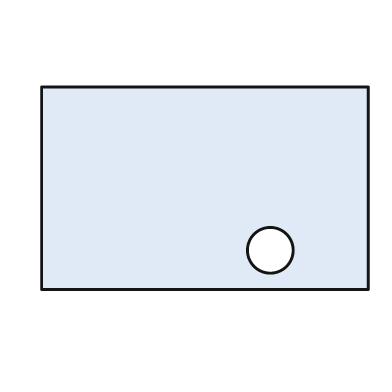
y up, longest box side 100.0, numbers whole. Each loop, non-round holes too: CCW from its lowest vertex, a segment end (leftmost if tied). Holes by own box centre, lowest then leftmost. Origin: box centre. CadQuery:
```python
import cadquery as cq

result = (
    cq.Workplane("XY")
    .moveTo(-50.0, -31.0)
    .lineTo(50.0, -31.0)
    .lineTo(50.0, 31.0)
    .lineTo(-50.0, 31.0)
    .close()
    .moveTo(20.0, -19.0)
    .circle(7.0)
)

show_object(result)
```